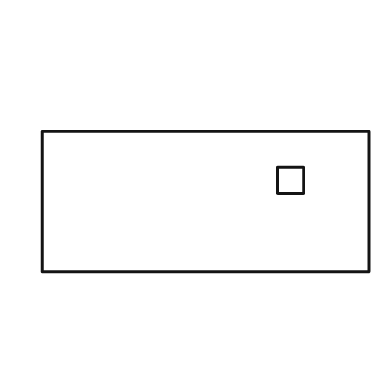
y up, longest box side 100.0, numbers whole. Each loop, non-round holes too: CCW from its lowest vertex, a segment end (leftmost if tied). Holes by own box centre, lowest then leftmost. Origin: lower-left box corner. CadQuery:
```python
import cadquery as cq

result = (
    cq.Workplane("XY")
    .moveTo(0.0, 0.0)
    .lineTo(100.0, 0.0)
    .lineTo(100.0, 43.0)
    .lineTo(0.0, 43.0)
    .close()
    .moveTo(72.0, 24.0)
    .lineTo(80.0, 24.0)
    .lineTo(80.0, 32.0)
    .lineTo(72.0, 32.0)
    .close()
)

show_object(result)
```